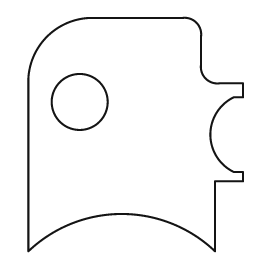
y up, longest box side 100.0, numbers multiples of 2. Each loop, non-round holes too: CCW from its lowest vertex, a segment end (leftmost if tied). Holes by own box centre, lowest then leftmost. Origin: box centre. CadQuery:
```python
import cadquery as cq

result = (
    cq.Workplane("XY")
    .moveTo(-46.0, -50.0)
    .threePointArc((-6.0, -34.0), (34.0, -50.0))
    .lineTo(34.0, -20.0)
    .lineTo(46.0, -20.0)
    .lineTo(46.0, -16.0)
    .lineTo(42.0, -16.0)
    .threePointArc((32.0, 0.0), (42.0, 16.0))
    .lineTo(46.0, 16.0)
    .lineTo(46.0, 22.0)
    .lineTo(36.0, 22.0)
    .threePointArc((30.0, 24.0), (28.0, 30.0))
    .lineTo(28.0, 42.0)
    .threePointArc((26.0, 48.0), (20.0, 50.0))
    .lineTo(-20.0, 50.0)
    .threePointArc((-38.0, 42.0), (-46.0, 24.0))
    .close()
    .moveTo(-24.0, 14.0)
    .circle(12.0)
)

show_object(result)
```